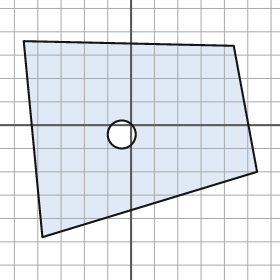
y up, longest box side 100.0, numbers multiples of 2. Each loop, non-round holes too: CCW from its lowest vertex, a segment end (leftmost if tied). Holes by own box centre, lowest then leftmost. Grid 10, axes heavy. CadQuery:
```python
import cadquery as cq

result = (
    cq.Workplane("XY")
    .moveTo(-38.0, -48.0)
    .lineTo(54.0, -20.0)
    .lineTo(44.0, 34.0)
    .lineTo(-46.0, 36.0)
    .close()
    .moveTo(-4.0, -4.0)
    .circle(6.0)
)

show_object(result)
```